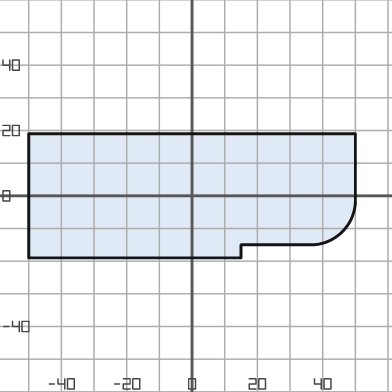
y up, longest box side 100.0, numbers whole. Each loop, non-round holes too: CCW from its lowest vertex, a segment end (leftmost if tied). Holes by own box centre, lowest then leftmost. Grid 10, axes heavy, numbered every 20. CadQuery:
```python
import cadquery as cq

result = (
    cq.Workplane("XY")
    .moveTo(-50.0, -19.0)
    .lineTo(15.0, -19.0)
    .lineTo(15.0, -15.0)
    .lineTo(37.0, -15.0)
    .threePointArc((46.0, -11.0), (50.0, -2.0))
    .lineTo(50.0, 19.0)
    .lineTo(-50.0, 19.0)
    .close()
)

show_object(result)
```